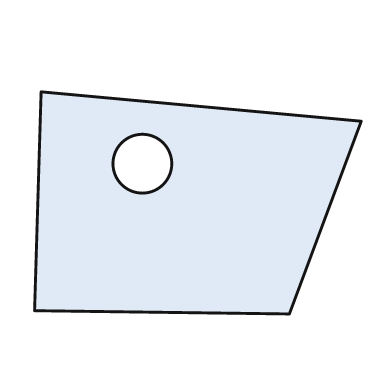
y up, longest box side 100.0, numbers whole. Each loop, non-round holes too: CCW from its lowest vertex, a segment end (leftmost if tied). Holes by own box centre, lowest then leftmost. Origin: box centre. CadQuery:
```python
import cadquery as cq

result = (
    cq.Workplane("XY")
    .moveTo(28.0, -34.0)
    .lineTo(50.0, 25.0)
    .lineTo(-48.0, 34.0)
    .lineTo(-50.0, -33.0)
    .close()
    .moveTo(-17.0, 12.0)
    .circle(9.0)
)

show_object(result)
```